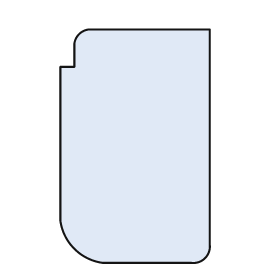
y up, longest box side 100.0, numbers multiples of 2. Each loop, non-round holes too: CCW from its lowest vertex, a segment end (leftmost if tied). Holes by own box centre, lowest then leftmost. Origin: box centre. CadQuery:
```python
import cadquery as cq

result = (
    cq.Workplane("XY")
    .moveTo(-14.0, -50.0)
    .lineTo(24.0, -50.0)
    .threePointArc((30.0, -48.0), (32.0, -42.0))
    .lineTo(32.0, 50.0)
    .lineTo(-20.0, 50.0)
    .threePointArc((-24.0, 48.0), (-26.0, 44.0))
    .lineTo(-26.0, 34.0)
    .lineTo(-32.0, 34.0)
    .lineTo(-32.0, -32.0)
    .threePointArc((-26.0, -44.0), (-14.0, -50.0))
    .close()
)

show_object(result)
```